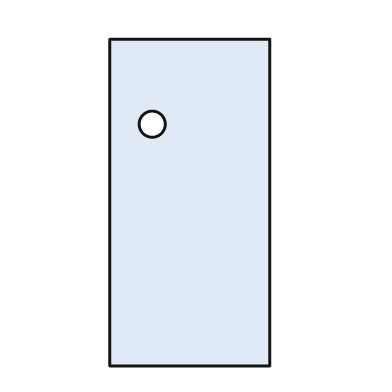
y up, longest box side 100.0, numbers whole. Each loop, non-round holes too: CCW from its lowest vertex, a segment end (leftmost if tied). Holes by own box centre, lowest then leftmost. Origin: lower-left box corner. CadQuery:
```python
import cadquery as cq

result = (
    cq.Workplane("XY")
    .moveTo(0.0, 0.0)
    .lineTo(49.0, 0.0)
    .lineTo(49.0, 100.0)
    .lineTo(0.0, 100.0)
    .close()
    .moveTo(13.0, 74.0)
    .circle(4.0)
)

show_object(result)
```